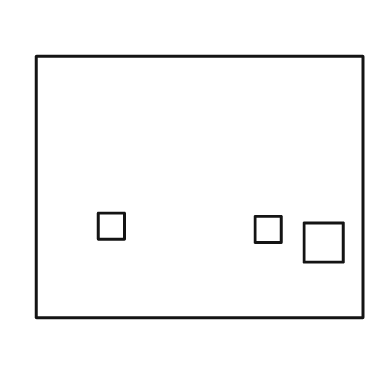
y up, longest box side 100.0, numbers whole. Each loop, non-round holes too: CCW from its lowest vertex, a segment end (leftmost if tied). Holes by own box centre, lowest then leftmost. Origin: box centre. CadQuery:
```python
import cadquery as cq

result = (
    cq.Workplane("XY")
    .moveTo(-50.0, -40.0)
    .lineTo(50.0, -40.0)
    .lineTo(50.0, 40.0)
    .lineTo(-50.0, 40.0)
    .close()
    .moveTo(32.0, -23.0)
    .lineTo(44.0, -23.0)
    .lineTo(44.0, -11.0)
    .lineTo(32.0, -11.0)
    .close()
    .moveTo(17.0, -17.0)
    .lineTo(25.0, -17.0)
    .lineTo(25.0, -9.0)
    .lineTo(17.0, -9.0)
    .close()
    .moveTo(-31.0, -16.0)
    .lineTo(-23.0, -16.0)
    .lineTo(-23.0, -8.0)
    .lineTo(-31.0, -8.0)
    .close()
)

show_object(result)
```